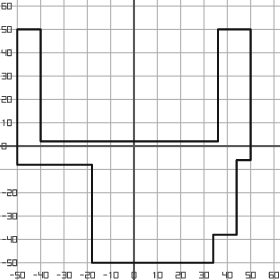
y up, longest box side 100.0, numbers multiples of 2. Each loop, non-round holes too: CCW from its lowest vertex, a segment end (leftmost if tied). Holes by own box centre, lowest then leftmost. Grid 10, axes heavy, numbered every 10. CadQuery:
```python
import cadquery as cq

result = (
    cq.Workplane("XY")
    .moveTo(-18.0, -50.0)
    .lineTo(34.0, -50.0)
    .lineTo(34.0, -38.0)
    .lineTo(44.0, -38.0)
    .lineTo(44.0, -6.0)
    .lineTo(50.0, -6.0)
    .lineTo(50.0, 50.0)
    .lineTo(36.0, 50.0)
    .lineTo(36.0, 2.0)
    .lineTo(-40.0, 2.0)
    .lineTo(-40.0, 50.0)
    .lineTo(-50.0, 50.0)
    .lineTo(-50.0, -8.0)
    .lineTo(-18.0, -8.0)
    .close()
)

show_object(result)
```